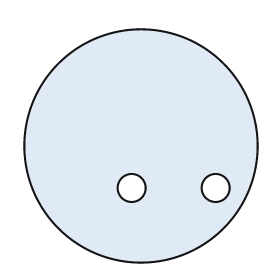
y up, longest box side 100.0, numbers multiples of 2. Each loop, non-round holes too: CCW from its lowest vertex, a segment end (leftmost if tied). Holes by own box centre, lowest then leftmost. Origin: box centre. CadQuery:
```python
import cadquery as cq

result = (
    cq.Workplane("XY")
    .moveTo(0.0, 0.0)
    .circle(50.0)
    .moveTo(-4.0, -18.0)
    .circle(6.0)
    .moveTo(32.0, -18.0)
    .circle(6.0)
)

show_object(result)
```